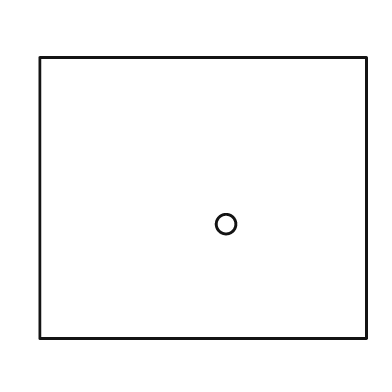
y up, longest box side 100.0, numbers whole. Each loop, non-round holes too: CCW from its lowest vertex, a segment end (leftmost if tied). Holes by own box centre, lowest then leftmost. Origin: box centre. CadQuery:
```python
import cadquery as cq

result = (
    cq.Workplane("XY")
    .moveTo(-50.0, -43.0)
    .lineTo(50.0, -43.0)
    .lineTo(50.0, 43.0)
    .lineTo(-50.0, 43.0)
    .close()
    .moveTo(7.0, -8.0)
    .circle(3.0)
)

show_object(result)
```